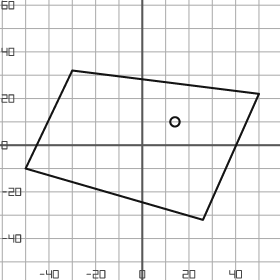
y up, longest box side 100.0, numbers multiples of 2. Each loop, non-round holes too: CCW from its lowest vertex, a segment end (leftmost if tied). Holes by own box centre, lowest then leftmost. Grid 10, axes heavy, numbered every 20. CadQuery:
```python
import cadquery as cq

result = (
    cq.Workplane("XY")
    .moveTo(26.0, -32.0)
    .lineTo(50.0, 22.0)
    .lineTo(-30.0, 32.0)
    .lineTo(-50.0, -10.0)
    .close()
    .moveTo(14.0, 10.0)
    .circle(2.0)
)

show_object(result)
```